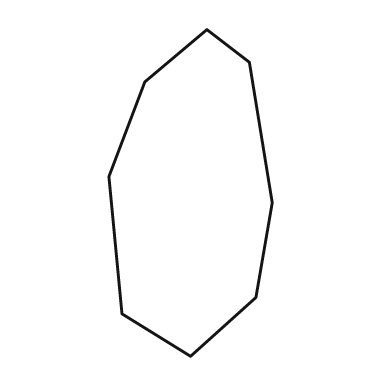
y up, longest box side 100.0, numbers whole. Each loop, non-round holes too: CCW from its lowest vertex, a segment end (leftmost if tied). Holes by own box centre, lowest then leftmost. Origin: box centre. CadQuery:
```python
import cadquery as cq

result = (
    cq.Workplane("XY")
    .moveTo(0.0, -50.0)
    .lineTo(20.0, -32.0)
    .lineTo(25.0, -3.0)
    .lineTo(18.0, 40.0)
    .lineTo(5.0, 50.0)
    .lineTo(-14.0, 34.0)
    .lineTo(-25.0, 5.0)
    .lineTo(-21.0, -37.0)
    .close()
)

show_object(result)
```